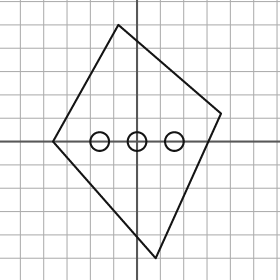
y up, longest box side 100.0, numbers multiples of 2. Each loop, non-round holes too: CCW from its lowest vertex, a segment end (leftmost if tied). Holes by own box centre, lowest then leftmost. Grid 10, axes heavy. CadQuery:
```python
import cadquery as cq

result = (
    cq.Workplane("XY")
    .moveTo(8.0, -50.0)
    .lineTo(36.0, 12.0)
    .lineTo(-8.0, 50.0)
    .lineTo(-36.0, 0.0)
    .close()
    .moveTo(-16.0, 0.0)
    .circle(4.0)
    .moveTo(0.0, 0.0)
    .circle(4.0)
    .moveTo(16.0, 0.0)
    .circle(4.0)
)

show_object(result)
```